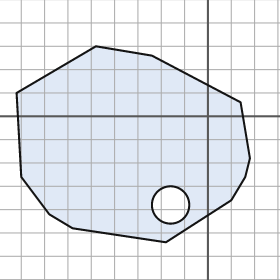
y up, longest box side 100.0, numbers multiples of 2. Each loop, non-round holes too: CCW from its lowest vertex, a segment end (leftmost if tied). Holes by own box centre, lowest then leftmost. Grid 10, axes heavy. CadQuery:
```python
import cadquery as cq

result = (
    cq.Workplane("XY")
    .moveTo(-18.0, -54.0)
    .lineTo(10.0, -36.0)
    .lineTo(16.0, -26.0)
    .lineTo(18.0, -18.0)
    .lineTo(14.0, 6.0)
    .lineTo(-24.0, 26.0)
    .lineTo(-48.0, 30.0)
    .lineTo(-82.0, 10.0)
    .lineTo(-80.0, -26.0)
    .lineTo(-68.0, -42.0)
    .lineTo(-58.0, -48.0)
    .close()
    .moveTo(-16.0, -38.0)
    .circle(8.0)
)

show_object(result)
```